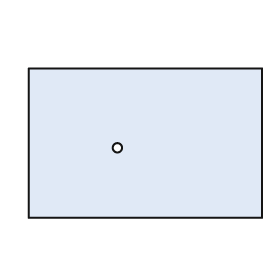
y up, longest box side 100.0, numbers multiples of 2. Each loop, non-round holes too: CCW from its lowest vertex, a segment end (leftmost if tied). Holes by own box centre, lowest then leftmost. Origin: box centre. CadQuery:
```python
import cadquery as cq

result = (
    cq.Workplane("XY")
    .moveTo(-50.0, -32.0)
    .lineTo(50.0, -32.0)
    .lineTo(50.0, 32.0)
    .lineTo(-50.0, 32.0)
    .close()
    .moveTo(-12.0, -2.0)
    .circle(2.0)
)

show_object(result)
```